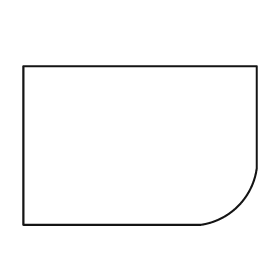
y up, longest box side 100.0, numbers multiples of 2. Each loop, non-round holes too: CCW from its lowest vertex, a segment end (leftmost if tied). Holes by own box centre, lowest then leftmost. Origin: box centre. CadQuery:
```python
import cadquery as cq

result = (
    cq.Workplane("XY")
    .moveTo(-50.0, -34.0)
    .lineTo(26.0, -34.0)
    .threePointArc((42.0, -26.0), (50.0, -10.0))
    .lineTo(50.0, 34.0)
    .lineTo(-50.0, 34.0)
    .close()
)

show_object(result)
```